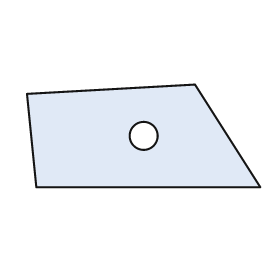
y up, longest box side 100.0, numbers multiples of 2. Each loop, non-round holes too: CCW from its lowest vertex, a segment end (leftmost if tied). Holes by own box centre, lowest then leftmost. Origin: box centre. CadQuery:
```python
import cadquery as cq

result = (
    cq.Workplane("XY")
    .moveTo(-46.0, -22.0)
    .lineTo(50.0, -22.0)
    .lineTo(22.0, 22.0)
    .lineTo(-50.0, 18.0)
    .close()
    .moveTo(0.0, 0.0)
    .circle(6.0)
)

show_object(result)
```